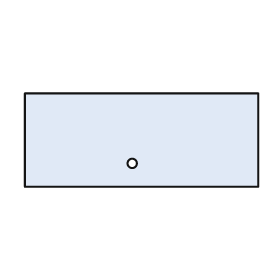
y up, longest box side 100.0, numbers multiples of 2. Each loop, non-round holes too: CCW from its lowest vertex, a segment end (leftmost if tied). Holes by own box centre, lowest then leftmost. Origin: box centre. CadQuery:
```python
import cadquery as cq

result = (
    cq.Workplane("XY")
    .moveTo(-50.0, -20.0)
    .lineTo(50.0, -20.0)
    .lineTo(50.0, 20.0)
    .lineTo(-50.0, 20.0)
    .close()
    .moveTo(-4.0, -10.0)
    .circle(2.0)
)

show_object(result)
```